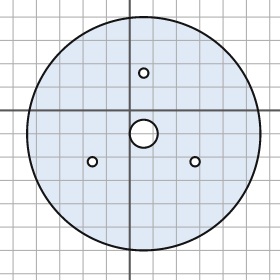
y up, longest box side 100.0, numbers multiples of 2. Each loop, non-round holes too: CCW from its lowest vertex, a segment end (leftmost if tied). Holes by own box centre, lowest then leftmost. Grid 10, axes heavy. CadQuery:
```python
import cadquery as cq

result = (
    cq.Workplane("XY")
    .moveTo(6.0, -10.0)
    .circle(50.0)
    .moveTo(-16.0, -22.0)
    .circle(2.0)
    .moveTo(28.0, -22.0)
    .circle(2.0)
    .moveTo(6.0, -10.0)
    .circle(6.0)
    .moveTo(6.0, 16.0)
    .circle(2.0)
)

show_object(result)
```